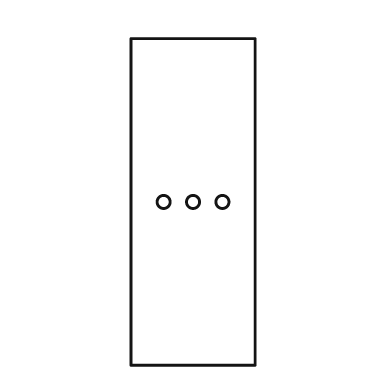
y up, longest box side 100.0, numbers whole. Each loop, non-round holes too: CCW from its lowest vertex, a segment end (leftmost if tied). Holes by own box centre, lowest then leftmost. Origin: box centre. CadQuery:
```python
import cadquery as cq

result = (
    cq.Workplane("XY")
    .moveTo(-19.0, -50.0)
    .lineTo(19.0, -50.0)
    .lineTo(19.0, 50.0)
    .lineTo(-19.0, 50.0)
    .close()
    .moveTo(-9.0, 0.0)
    .circle(2.0)
    .moveTo(0.0, 0.0)
    .circle(2.0)
    .moveTo(9.0, 0.0)
    .circle(2.0)
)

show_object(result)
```